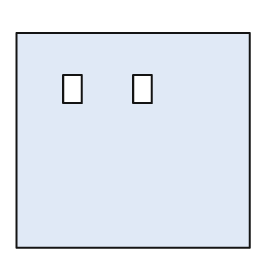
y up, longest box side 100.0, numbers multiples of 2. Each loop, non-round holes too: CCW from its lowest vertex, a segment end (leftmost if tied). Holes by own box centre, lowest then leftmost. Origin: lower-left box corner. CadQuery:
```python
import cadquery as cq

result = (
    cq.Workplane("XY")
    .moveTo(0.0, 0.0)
    .lineTo(100.0, 0.0)
    .lineTo(100.0, 92.0)
    .lineTo(0.0, 92.0)
    .close()
    .moveTo(20.0, 62.0)
    .lineTo(28.0, 62.0)
    .lineTo(28.0, 74.0)
    .lineTo(20.0, 74.0)
    .close()
    .moveTo(50.0, 62.0)
    .lineTo(58.0, 62.0)
    .lineTo(58.0, 74.0)
    .lineTo(50.0, 74.0)
    .close()
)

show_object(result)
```